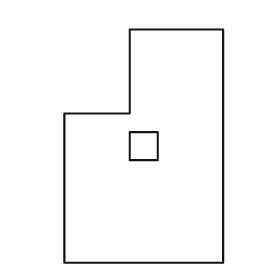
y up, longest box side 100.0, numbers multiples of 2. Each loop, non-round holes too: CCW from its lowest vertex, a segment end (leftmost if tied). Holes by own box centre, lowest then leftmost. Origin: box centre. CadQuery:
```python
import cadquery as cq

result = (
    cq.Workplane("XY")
    .moveTo(-34.0, -50.0)
    .lineTo(34.0, -50.0)
    .lineTo(34.0, 50.0)
    .lineTo(-6.0, 50.0)
    .lineTo(-6.0, 14.0)
    .lineTo(-34.0, 14.0)
    .close()
    .moveTo(-6.0, -6.0)
    .lineTo(6.0, -6.0)
    .lineTo(6.0, 6.0)
    .lineTo(-6.0, 6.0)
    .close()
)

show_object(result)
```